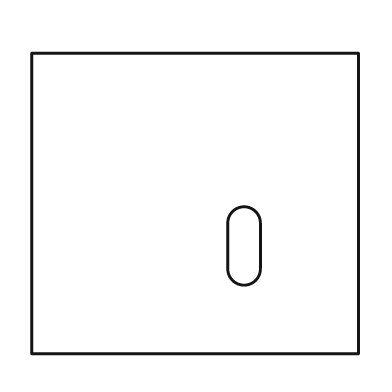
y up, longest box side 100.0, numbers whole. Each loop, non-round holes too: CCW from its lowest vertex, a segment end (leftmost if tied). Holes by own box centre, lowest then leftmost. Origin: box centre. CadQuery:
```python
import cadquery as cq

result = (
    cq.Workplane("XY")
    .moveTo(-50.0, -46.0)
    .lineTo(50.0, -46.0)
    .lineTo(50.0, 46.0)
    .lineTo(-50.0, 46.0)
    .close()
    .moveTo(10.0, -20.0)
    .threePointArc((15.0, -25.0), (20.0, -20.0))
    .lineTo(20.0, -6.0)
    .threePointArc((15.0, -1.0), (10.0, -6.0))
    .close()
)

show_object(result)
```